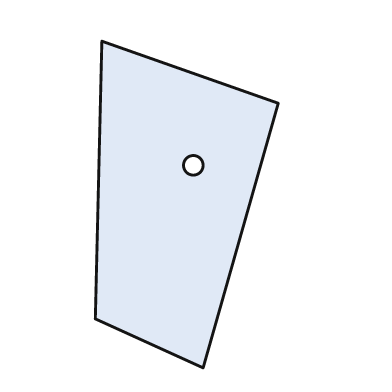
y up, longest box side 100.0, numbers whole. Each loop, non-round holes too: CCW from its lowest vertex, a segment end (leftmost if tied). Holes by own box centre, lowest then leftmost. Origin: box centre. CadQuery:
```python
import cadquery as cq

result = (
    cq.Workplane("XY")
    .moveTo(5.0, -50.0)
    .lineTo(28.0, 31.0)
    .lineTo(-26.0, 50.0)
    .lineTo(-28.0, -35.0)
    .close()
    .moveTo(2.0, 12.0)
    .circle(3.0)
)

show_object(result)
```